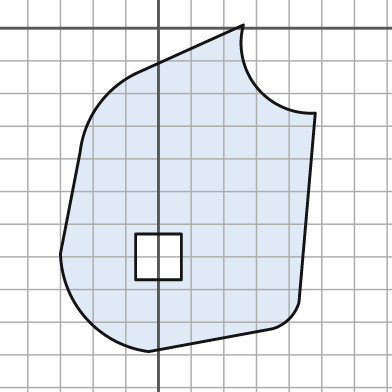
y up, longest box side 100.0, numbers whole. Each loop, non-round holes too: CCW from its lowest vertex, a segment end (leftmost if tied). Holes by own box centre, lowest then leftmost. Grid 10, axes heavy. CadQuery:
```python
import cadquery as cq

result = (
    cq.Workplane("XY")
    .moveTo(-3.0, -99.0)
    .lineTo(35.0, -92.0)
    .threePointArc((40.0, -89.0), (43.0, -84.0))
    .lineTo(48.0, -26.0)
    .threePointArc((30.0, -18.0), (26.0, 1.0))
    .lineTo(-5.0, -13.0)
    .threePointArc((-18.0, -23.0), (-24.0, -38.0))
    .lineTo(-30.0, -69.0)
    .threePointArc((-22.0, -89.0), (-3.0, -99.0))
    .close()
    .moveTo(-7.0, -77.0)
    .lineTo(7.0, -77.0)
    .lineTo(7.0, -63.0)
    .lineTo(-7.0, -63.0)
    .close()
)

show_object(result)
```